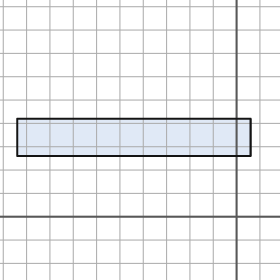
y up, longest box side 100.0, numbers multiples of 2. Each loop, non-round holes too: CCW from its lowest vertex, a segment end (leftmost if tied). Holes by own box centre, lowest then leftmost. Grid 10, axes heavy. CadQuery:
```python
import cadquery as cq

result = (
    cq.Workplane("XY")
    .moveTo(-94.0, 26.0)
    .lineTo(6.0, 26.0)
    .lineTo(6.0, 42.0)
    .lineTo(-94.0, 42.0)
    .close()
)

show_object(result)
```